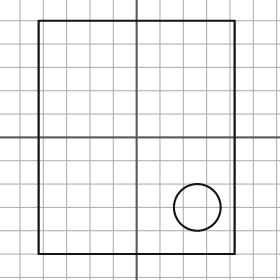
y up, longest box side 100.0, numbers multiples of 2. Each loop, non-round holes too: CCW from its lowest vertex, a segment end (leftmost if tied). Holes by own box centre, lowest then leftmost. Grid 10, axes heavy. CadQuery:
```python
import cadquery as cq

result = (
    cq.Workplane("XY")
    .moveTo(-42.0, -50.0)
    .lineTo(42.0, -50.0)
    .lineTo(42.0, 50.0)
    .lineTo(-42.0, 50.0)
    .close()
    .moveTo(26.0, -30.0)
    .circle(10.0)
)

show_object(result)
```